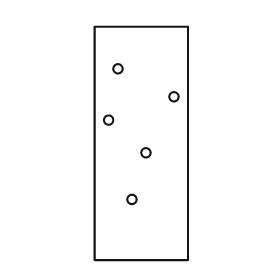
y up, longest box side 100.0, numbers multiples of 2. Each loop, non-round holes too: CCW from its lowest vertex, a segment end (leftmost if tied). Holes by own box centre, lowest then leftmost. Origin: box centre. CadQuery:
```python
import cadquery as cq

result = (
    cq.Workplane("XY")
    .moveTo(-20.0, -50.0)
    .lineTo(20.0, -50.0)
    .lineTo(20.0, 50.0)
    .lineTo(-20.0, 50.0)
    .close()
    .moveTo(-4.0, -24.0)
    .circle(2.0)
    .moveTo(2.0, -4.0)
    .circle(2.0)
    .moveTo(-14.0, 10.0)
    .circle(2.0)
    .moveTo(14.0, 20.0)
    .circle(2.0)
    .moveTo(-10.0, 32.0)
    .circle(2.0)
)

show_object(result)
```